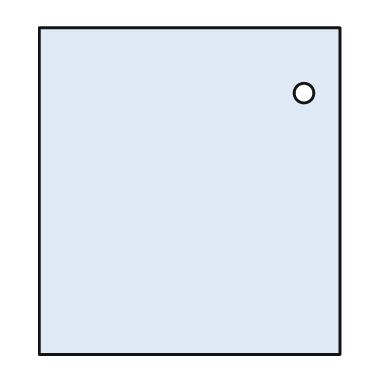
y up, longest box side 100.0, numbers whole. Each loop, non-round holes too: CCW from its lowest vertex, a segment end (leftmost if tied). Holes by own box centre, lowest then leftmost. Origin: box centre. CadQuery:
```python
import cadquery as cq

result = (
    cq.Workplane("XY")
    .moveTo(-46.0, -50.0)
    .lineTo(46.0, -50.0)
    .lineTo(46.0, 50.0)
    .lineTo(-46.0, 50.0)
    .close()
    .moveTo(35.0, 30.0)
    .circle(3.0)
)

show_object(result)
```